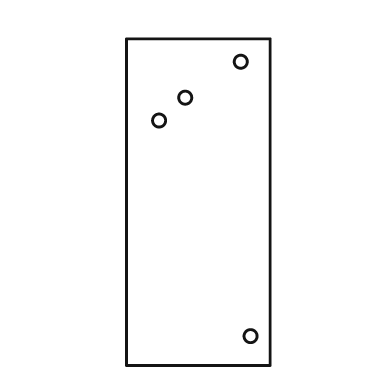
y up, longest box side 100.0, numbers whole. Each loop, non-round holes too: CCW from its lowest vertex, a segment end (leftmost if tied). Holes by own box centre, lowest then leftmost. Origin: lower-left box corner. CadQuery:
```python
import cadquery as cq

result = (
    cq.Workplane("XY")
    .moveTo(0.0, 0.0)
    .lineTo(44.0, 0.0)
    .lineTo(44.0, 100.0)
    .lineTo(0.0, 100.0)
    .close()
    .moveTo(38.0, 9.0)
    .circle(2.0)
    .moveTo(10.0, 75.0)
    .circle(2.0)
    .moveTo(18.0, 82.0)
    .circle(2.0)
    .moveTo(35.0, 93.0)
    .circle(2.0)
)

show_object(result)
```